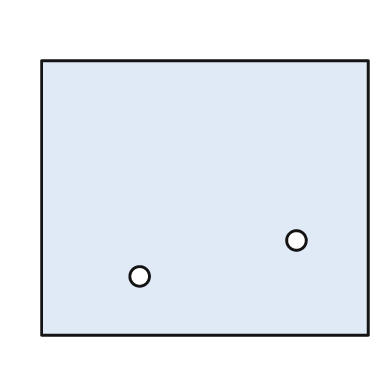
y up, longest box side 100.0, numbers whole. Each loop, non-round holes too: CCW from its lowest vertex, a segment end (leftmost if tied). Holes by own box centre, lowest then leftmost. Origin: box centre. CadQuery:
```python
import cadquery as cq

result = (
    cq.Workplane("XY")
    .moveTo(-50.0, -42.0)
    .lineTo(50.0, -42.0)
    .lineTo(50.0, 42.0)
    .lineTo(-50.0, 42.0)
    .close()
    .moveTo(-20.0, -24.0)
    .circle(3.0)
    .moveTo(28.0, -13.0)
    .circle(3.0)
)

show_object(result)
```